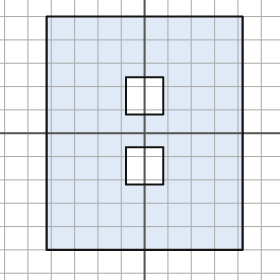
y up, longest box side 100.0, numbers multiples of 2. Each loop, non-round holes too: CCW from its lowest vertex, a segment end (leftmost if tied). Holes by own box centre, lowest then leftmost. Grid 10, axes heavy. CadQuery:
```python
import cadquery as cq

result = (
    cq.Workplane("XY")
    .moveTo(-42.0, -50.0)
    .lineTo(42.0, -50.0)
    .lineTo(42.0, 50.0)
    .lineTo(-42.0, 50.0)
    .close()
    .moveTo(-8.0, -22.0)
    .lineTo(8.0, -22.0)
    .lineTo(8.0, -6.0)
    .lineTo(-8.0, -6.0)
    .close()
    .moveTo(-8.0, 8.0)
    .lineTo(8.0, 8.0)
    .lineTo(8.0, 24.0)
    .lineTo(-8.0, 24.0)
    .close()
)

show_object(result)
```